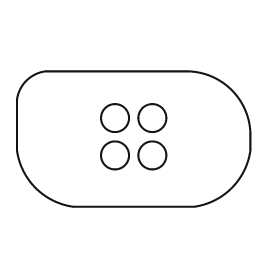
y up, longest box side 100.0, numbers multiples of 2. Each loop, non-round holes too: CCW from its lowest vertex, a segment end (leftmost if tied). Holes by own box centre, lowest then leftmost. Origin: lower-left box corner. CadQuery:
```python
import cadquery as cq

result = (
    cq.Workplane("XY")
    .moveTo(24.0, 0.0)
    .lineTo(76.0, 0.0)
    .threePointArc((92.0, 8.0), (100.0, 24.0))
    .lineTo(100.0, 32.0)
    .threePointArc((92.0, 50.0), (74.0, 58.0))
    .lineTo(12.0, 58.0)
    .threePointArc((4.0, 54.0), (0.0, 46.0))
    .lineTo(0.0, 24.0)
    .threePointArc((8.0, 8.0), (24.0, 0.0))
    .close()
    .moveTo(42.0, 22.0)
    .circle(6.0)
    .moveTo(58.0, 22.0)
    .circle(6.0)
    .moveTo(42.0, 38.0)
    .circle(6.0)
    .moveTo(58.0, 38.0)
    .circle(6.0)
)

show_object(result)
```